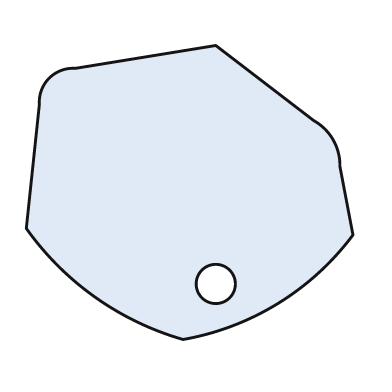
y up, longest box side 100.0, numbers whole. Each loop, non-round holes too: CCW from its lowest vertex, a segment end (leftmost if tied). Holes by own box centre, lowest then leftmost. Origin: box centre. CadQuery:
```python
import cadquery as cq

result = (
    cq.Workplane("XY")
    .moveTo(-2.0, -45.0)
    .threePointArc((27.0, -34.0), (50.0, -13.0))
    .lineTo(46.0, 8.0)
    .threePointArc((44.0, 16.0), (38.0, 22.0))
    .lineTo(8.0, 45.0)
    .lineTo(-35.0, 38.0)
    .threePointArc((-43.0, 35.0), (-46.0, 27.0))
    .lineTo(-50.0, -11.0)
    .threePointArc((-29.0, -32.0), (-2.0, -45.0))
    .close()
    .moveTo(8.0, -28.0)
    .circle(6.0)
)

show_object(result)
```